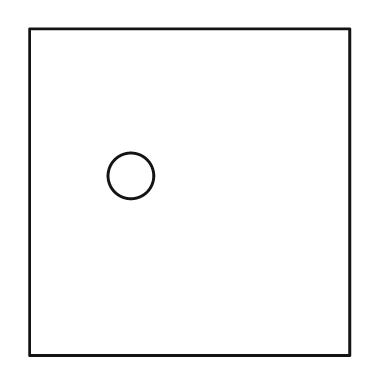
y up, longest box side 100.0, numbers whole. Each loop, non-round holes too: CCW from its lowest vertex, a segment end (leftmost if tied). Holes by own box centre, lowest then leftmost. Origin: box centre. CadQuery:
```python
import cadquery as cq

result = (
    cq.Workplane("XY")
    .moveTo(-49.0, -50.0)
    .lineTo(49.0, -50.0)
    .lineTo(49.0, 50.0)
    .lineTo(-49.0, 50.0)
    .close()
    .moveTo(-18.0, 5.0)
    .circle(7.0)
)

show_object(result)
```